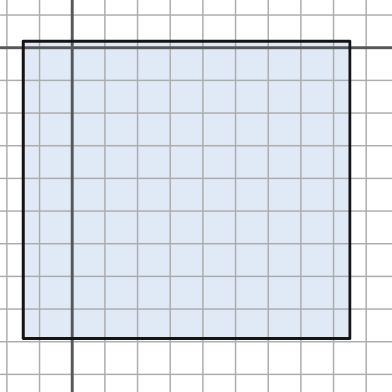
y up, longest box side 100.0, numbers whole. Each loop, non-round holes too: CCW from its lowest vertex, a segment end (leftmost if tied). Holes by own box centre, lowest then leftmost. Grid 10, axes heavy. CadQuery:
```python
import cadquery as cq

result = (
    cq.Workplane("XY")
    .moveTo(-15.0, -89.0)
    .lineTo(85.0, -89.0)
    .lineTo(85.0, 2.0)
    .lineTo(-15.0, 2.0)
    .close()
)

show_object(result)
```